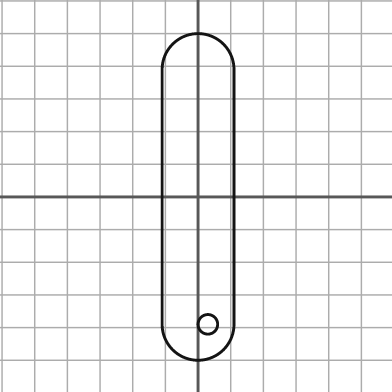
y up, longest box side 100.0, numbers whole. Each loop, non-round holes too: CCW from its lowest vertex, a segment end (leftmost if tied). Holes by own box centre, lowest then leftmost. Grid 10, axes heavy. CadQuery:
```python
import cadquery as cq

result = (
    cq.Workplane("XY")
    .moveTo(-11.0, -39.0)
    .threePointArc((0.0, -50.0), (11.0, -39.0))
    .lineTo(11.0, 39.0)
    .threePointArc((0.0, 50.0), (-11.0, 39.0))
    .close()
    .moveTo(3.0, -39.0)
    .circle(3.0)
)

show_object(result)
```